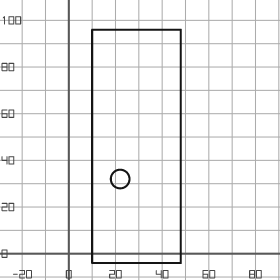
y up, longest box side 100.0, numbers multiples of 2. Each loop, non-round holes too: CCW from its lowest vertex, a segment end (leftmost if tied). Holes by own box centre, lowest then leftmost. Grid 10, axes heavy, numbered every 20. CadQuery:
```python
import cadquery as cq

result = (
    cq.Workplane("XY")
    .moveTo(10.0, -4.0)
    .lineTo(48.0, -4.0)
    .lineTo(48.0, 96.0)
    .lineTo(10.0, 96.0)
    .close()
    .moveTo(22.0, 32.0)
    .circle(4.0)
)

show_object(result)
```